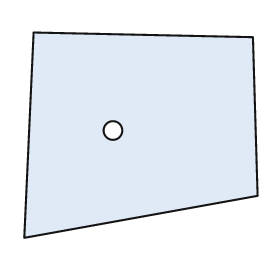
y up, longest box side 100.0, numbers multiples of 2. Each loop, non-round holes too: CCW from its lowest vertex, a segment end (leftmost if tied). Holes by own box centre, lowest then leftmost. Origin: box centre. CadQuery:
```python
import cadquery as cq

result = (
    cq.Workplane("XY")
    .moveTo(-50.0, -44.0)
    .lineTo(50.0, -26.0)
    .lineTo(48.0, 42.0)
    .lineTo(-46.0, 44.0)
    .close()
    .moveTo(-12.0, 2.0)
    .circle(4.0)
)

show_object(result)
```